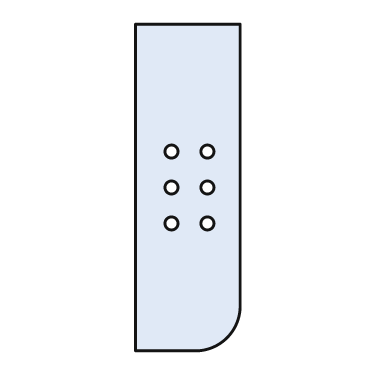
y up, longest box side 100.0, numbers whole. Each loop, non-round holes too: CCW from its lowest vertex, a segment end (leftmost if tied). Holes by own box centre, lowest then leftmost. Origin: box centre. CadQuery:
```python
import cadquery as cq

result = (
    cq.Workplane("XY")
    .moveTo(-16.0, -50.0)
    .lineTo(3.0, -50.0)
    .threePointArc((12.0, -46.0), (16.0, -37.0))
    .lineTo(16.0, 50.0)
    .lineTo(-16.0, 50.0)
    .close()
    .moveTo(-5.0, -11.0)
    .circle(2.0)
    .moveTo(6.0, -11.0)
    .circle(2.0)
    .moveTo(-5.0, 0.0)
    .circle(2.0)
    .moveTo(6.0, 0.0)
    .circle(2.0)
    .moveTo(-5.0, 11.0)
    .circle(2.0)
    .moveTo(6.0, 11.0)
    .circle(2.0)
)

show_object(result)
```